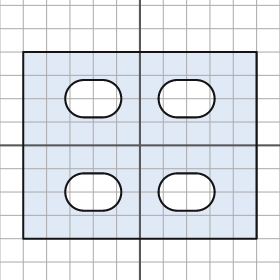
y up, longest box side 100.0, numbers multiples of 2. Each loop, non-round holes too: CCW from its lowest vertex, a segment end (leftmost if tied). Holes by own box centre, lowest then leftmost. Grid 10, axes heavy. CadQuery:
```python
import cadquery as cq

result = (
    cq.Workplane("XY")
    .moveTo(-50.0, -40.0)
    .lineTo(50.0, -40.0)
    .lineTo(50.0, 40.0)
    .lineTo(-50.0, 40.0)
    .close()
    .moveTo(-24.0, -28.0)
    .lineTo(-16.0, -28.0)
    .threePointArc((-8.0, -20.0), (-16.0, -12.0))
    .lineTo(-24.0, -12.0)
    .threePointArc((-32.0, -20.0), (-24.0, -28.0))
    .close()
    .moveTo(16.0, -28.0)
    .lineTo(24.0, -28.0)
    .threePointArc((32.0, -20.0), (24.0, -12.0))
    .lineTo(16.0, -12.0)
    .threePointArc((8.0, -20.0), (16.0, -28.0))
    .close()
    .moveTo(-24.0, 12.0)
    .lineTo(-16.0, 12.0)
    .threePointArc((-8.0, 20.0), (-16.0, 28.0))
    .lineTo(-24.0, 28.0)
    .threePointArc((-32.0, 20.0), (-24.0, 12.0))
    .close()
    .moveTo(16.0, 12.0)
    .lineTo(24.0, 12.0)
    .threePointArc((32.0, 20.0), (24.0, 28.0))
    .lineTo(16.0, 28.0)
    .threePointArc((8.0, 20.0), (16.0, 12.0))
    .close()
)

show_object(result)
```